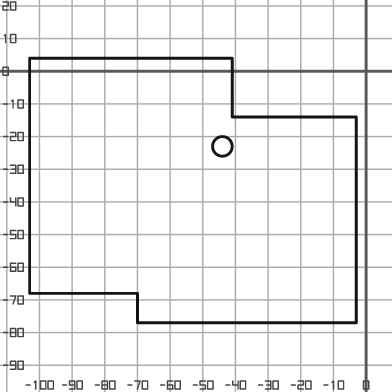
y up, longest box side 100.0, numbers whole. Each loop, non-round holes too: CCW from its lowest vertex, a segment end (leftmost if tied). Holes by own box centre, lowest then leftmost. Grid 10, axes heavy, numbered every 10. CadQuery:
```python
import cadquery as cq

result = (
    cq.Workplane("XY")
    .moveTo(-70.0, -77.0)
    .lineTo(-3.0, -77.0)
    .lineTo(-3.0, -14.0)
    .lineTo(-41.0, -14.0)
    .lineTo(-41.0, 4.0)
    .lineTo(-103.0, 4.0)
    .lineTo(-103.0, -68.0)
    .lineTo(-70.0, -68.0)
    .close()
    .moveTo(-44.0, -23.0)
    .circle(3.0)
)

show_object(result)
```